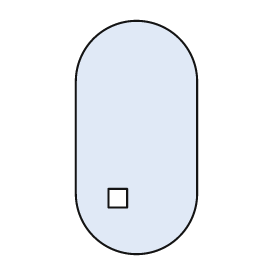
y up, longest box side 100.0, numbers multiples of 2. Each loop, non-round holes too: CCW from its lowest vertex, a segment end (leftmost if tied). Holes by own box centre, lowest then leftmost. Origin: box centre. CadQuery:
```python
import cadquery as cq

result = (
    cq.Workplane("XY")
    .moveTo(-26.0, -24.0)
    .threePointArc((0.0, -50.0), (26.0, -24.0))
    .lineTo(26.0, 24.0)
    .threePointArc((0.0, 50.0), (-26.0, 24.0))
    .close()
    .moveTo(-12.0, -30.0)
    .lineTo(-4.0, -30.0)
    .lineTo(-4.0, -22.0)
    .lineTo(-12.0, -22.0)
    .close()
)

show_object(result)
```